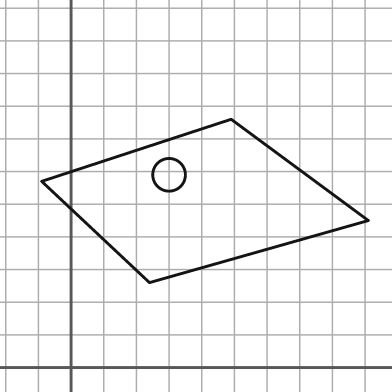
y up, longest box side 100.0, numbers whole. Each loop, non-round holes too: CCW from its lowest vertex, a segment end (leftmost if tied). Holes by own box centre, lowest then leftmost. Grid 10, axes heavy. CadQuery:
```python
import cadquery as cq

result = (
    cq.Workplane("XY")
    .moveTo(24.0, 26.0)
    .lineTo(91.0, 45.0)
    .lineTo(49.0, 76.0)
    .lineTo(-9.0, 57.0)
    .close()
    .moveTo(30.0, 59.0)
    .circle(5.0)
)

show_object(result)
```